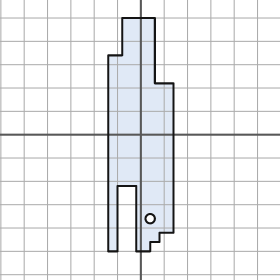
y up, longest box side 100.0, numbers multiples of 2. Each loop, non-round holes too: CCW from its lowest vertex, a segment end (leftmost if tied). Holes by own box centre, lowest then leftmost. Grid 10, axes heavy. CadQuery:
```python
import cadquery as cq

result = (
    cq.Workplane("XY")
    .moveTo(-14.0, -50.0)
    .lineTo(-10.0, -50.0)
    .lineTo(-10.0, -22.0)
    .lineTo(-2.0, -22.0)
    .lineTo(-2.0, -50.0)
    .lineTo(4.0, -50.0)
    .lineTo(4.0, -46.0)
    .lineTo(8.0, -46.0)
    .lineTo(8.0, -42.0)
    .lineTo(14.0, -42.0)
    .lineTo(14.0, 22.0)
    .lineTo(6.0, 22.0)
    .lineTo(6.0, 50.0)
    .lineTo(-8.0, 50.0)
    .lineTo(-8.0, 34.0)
    .lineTo(-14.0, 34.0)
    .close()
    .moveTo(4.0, -36.0)
    .circle(2.0)
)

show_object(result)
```